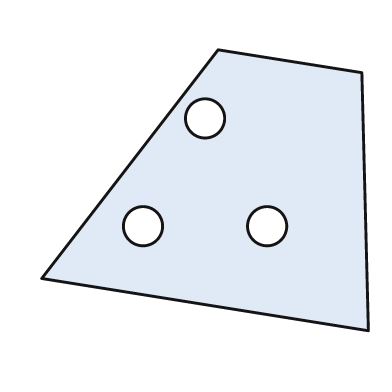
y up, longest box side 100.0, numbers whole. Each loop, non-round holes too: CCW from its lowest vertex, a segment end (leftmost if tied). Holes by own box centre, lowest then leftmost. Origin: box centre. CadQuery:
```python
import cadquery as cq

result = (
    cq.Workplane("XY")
    .moveTo(50.0, -43.0)
    .lineTo(48.0, 36.0)
    .lineTo(4.0, 43.0)
    .lineTo(-50.0, -27.0)
    .close()
    .moveTo(-19.0, -11.0)
    .circle(6.0)
    .moveTo(19.0, -11.0)
    .circle(6.0)
    .moveTo(0.0, 22.0)
    .circle(6.0)
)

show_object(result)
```